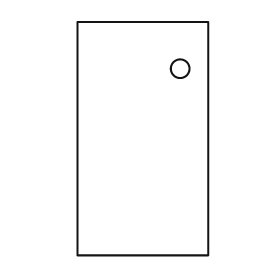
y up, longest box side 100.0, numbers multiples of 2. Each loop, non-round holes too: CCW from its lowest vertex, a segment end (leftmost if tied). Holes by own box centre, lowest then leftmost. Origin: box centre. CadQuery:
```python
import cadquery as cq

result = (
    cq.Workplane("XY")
    .moveTo(-28.0, -50.0)
    .lineTo(28.0, -50.0)
    .lineTo(28.0, 50.0)
    .lineTo(-28.0, 50.0)
    .close()
    .moveTo(16.0, 30.0)
    .circle(4.0)
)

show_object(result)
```